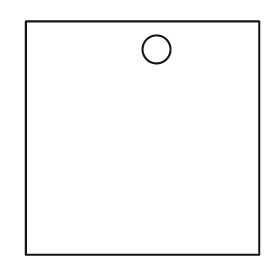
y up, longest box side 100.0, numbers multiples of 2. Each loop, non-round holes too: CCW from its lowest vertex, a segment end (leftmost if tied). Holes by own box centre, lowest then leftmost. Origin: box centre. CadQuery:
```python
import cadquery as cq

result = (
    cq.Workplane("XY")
    .moveTo(-50.0, -50.0)
    .lineTo(50.0, -50.0)
    .lineTo(50.0, 50.0)
    .lineTo(-50.0, 50.0)
    .close()
    .moveTo(6.0, 38.0)
    .circle(6.0)
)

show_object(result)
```